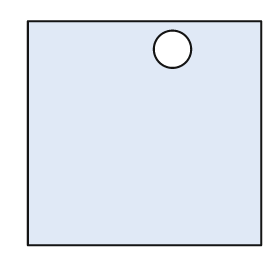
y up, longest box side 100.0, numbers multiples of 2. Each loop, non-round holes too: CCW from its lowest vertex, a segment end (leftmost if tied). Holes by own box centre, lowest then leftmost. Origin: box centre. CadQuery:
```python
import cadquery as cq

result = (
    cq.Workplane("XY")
    .moveTo(-50.0, -48.0)
    .lineTo(50.0, -48.0)
    .lineTo(50.0, 48.0)
    .lineTo(-50.0, 48.0)
    .close()
    .moveTo(12.0, 36.0)
    .circle(8.0)
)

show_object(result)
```